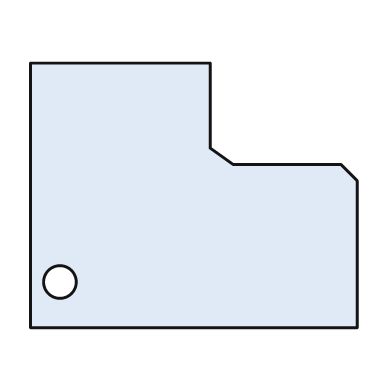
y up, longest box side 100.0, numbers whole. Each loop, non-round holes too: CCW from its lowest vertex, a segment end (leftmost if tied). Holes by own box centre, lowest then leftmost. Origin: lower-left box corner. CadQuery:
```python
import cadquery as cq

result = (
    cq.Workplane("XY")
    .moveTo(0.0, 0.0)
    .lineTo(100.0, 0.0)
    .lineTo(100.0, 45.0)
    .lineTo(95.0, 50.0)
    .lineTo(62.0, 50.0)
    .lineTo(55.0, 55.0)
    .lineTo(55.0, 81.0)
    .lineTo(0.0, 81.0)
    .close()
    .moveTo(9.0, 14.0)
    .circle(5.0)
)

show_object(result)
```